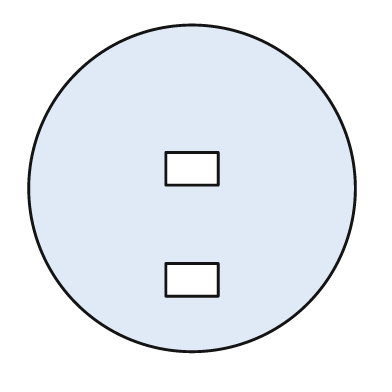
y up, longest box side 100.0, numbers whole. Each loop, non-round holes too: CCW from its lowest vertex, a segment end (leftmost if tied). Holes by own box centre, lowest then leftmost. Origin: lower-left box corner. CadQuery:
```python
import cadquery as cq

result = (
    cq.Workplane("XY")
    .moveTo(50.0, 50.0)
    .circle(50.0)
    .moveTo(42.0, 17.0)
    .lineTo(58.0, 17.0)
    .lineTo(58.0, 27.0)
    .lineTo(42.0, 27.0)
    .close()
    .moveTo(42.0, 51.0)
    .lineTo(58.0, 51.0)
    .lineTo(58.0, 61.0)
    .lineTo(42.0, 61.0)
    .close()
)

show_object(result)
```